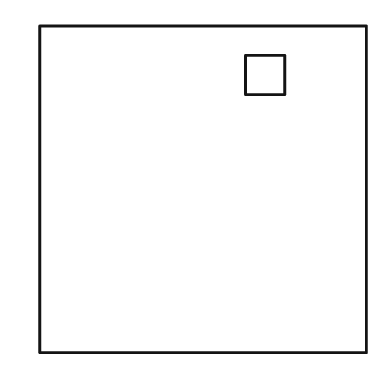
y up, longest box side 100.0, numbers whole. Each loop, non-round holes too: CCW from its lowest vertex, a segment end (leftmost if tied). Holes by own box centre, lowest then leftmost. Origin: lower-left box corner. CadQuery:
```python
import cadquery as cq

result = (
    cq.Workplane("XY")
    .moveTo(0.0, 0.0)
    .lineTo(100.0, 0.0)
    .lineTo(100.0, 100.0)
    .lineTo(0.0, 100.0)
    .close()
    .moveTo(63.0, 79.0)
    .lineTo(75.0, 79.0)
    .lineTo(75.0, 91.0)
    .lineTo(63.0, 91.0)
    .close()
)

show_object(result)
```